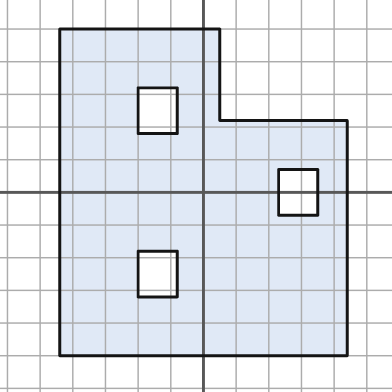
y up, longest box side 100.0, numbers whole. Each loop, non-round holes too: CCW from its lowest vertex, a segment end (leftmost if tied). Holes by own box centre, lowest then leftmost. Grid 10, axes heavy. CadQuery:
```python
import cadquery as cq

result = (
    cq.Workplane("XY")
    .moveTo(-44.0, -50.0)
    .lineTo(44.0, -50.0)
    .lineTo(44.0, 22.0)
    .lineTo(5.0, 22.0)
    .lineTo(5.0, 50.0)
    .lineTo(-44.0, 50.0)
    .close()
    .moveTo(-20.0, -32.0)
    .lineTo(-8.0, -32.0)
    .lineTo(-8.0, -18.0)
    .lineTo(-20.0, -18.0)
    .close()
    .moveTo(23.0, -7.0)
    .lineTo(35.0, -7.0)
    .lineTo(35.0, 7.0)
    .lineTo(23.0, 7.0)
    .close()
    .moveTo(-20.0, 18.0)
    .lineTo(-8.0, 18.0)
    .lineTo(-8.0, 32.0)
    .lineTo(-20.0, 32.0)
    .close()
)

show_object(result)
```